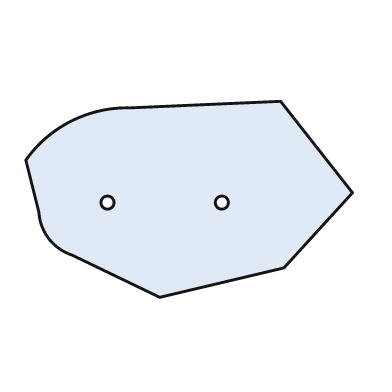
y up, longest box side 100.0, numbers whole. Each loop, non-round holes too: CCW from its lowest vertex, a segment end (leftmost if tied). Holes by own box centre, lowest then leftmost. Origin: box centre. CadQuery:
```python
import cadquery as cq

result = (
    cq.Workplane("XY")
    .moveTo(-9.0, -30.0)
    .lineTo(29.0, -21.0)
    .lineTo(50.0, 2.0)
    .lineTo(28.0, 30.0)
    .lineTo(-18.0, 28.0)
    .threePointArc((-36.0, 24.0), (-50.0, 12.0))
    .lineTo(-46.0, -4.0)
    .threePointArc((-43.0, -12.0), (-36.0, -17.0))
    .close()
    .moveTo(-25.0, -1.0)
    .circle(2.0)
    .moveTo(10.0, -1.0)
    .circle(2.0)
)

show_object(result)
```